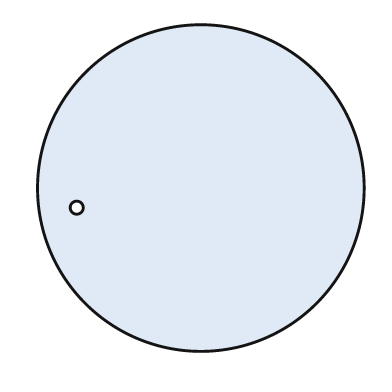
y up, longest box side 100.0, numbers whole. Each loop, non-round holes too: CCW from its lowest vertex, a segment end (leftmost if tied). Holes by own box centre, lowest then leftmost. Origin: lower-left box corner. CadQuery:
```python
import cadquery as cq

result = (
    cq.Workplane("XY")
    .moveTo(50.0, 50.0)
    .circle(50.0)
    .moveTo(12.0, 44.0)
    .circle(2.0)
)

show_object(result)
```